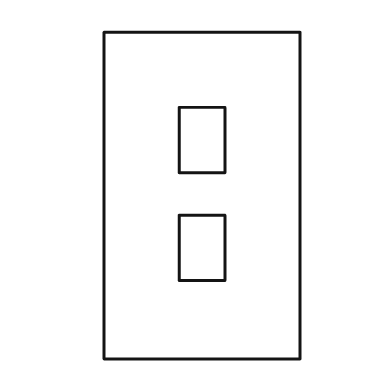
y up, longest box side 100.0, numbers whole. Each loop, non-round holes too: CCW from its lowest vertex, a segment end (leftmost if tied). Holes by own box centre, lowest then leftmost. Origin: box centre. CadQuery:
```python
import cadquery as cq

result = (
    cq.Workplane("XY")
    .moveTo(-30.0, -50.0)
    .lineTo(30.0, -50.0)
    .lineTo(30.0, 50.0)
    .lineTo(-30.0, 50.0)
    .close()
    .moveTo(-7.0, -26.0)
    .lineTo(7.0, -26.0)
    .lineTo(7.0, -6.0)
    .lineTo(-7.0, -6.0)
    .close()
    .moveTo(-7.0, 7.0)
    .lineTo(7.0, 7.0)
    .lineTo(7.0, 27.0)
    .lineTo(-7.0, 27.0)
    .close()
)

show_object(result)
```